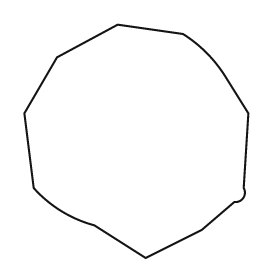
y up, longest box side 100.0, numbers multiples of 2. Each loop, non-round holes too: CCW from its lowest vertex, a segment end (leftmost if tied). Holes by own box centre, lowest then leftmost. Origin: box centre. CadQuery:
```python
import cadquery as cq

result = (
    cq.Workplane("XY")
    .moveTo(4.0, -50.0)
    .lineTo(28.0, -38.0)
    .lineTo(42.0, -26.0)
    .threePointArc((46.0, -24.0), (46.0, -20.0))
    .lineTo(48.0, 12.0)
    .lineTo(38.0, 28.0)
    .threePointArc((30.0, 38.0), (20.0, 46.0))
    .lineTo(-8.0, 50.0)
    .lineTo(-34.0, 36.0)
    .lineTo(-48.0, 12.0)
    .lineTo(-44.0, -20.0)
    .threePointArc((-32.0, -30.0), (-18.0, -36.0))
    .close()
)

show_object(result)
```